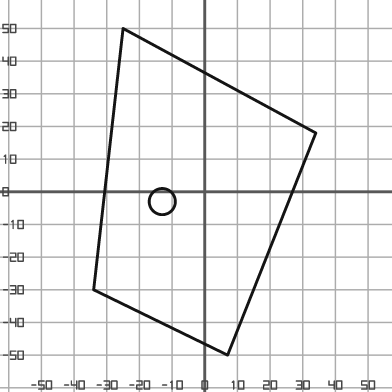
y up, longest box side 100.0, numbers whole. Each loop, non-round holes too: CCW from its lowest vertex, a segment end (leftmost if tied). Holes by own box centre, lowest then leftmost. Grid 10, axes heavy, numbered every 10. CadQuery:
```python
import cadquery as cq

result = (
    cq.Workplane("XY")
    .moveTo(7.0, -50.0)
    .lineTo(34.0, 18.0)
    .lineTo(-25.0, 50.0)
    .lineTo(-34.0, -30.0)
    .close()
    .moveTo(-13.0, -3.0)
    .circle(4.0)
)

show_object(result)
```